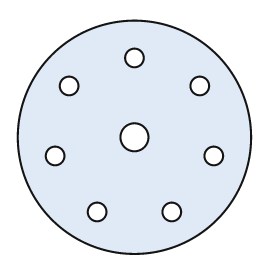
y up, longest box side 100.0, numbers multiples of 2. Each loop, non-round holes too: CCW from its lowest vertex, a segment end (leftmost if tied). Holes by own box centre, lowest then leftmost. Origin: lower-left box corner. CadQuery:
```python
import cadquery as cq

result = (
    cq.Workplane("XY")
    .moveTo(50.0, 50.0)
    .circle(50.0)
    .moveTo(34.0, 18.0)
    .circle(4.0)
    .moveTo(66.0, 18.0)
    .circle(4.0)
    .moveTo(16.0, 42.0)
    .circle(4.0)
    .moveTo(84.0, 42.0)
    .circle(4.0)
    .moveTo(50.0, 50.0)
    .circle(6.0)
    .moveTo(22.0, 72.0)
    .circle(4.0)
    .moveTo(78.0, 72.0)
    .circle(4.0)
    .moveTo(50.0, 84.0)
    .circle(4.0)
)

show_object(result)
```